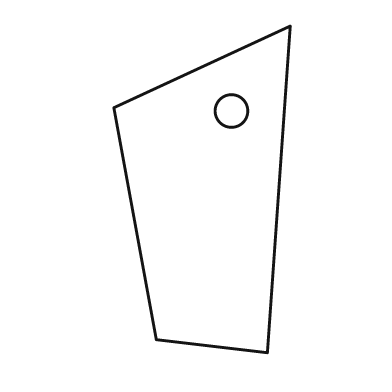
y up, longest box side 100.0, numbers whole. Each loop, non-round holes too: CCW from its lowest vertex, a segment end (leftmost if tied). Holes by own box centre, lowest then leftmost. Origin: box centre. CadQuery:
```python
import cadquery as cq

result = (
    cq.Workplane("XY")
    .moveTo(20.0, -50.0)
    .lineTo(27.0, 50.0)
    .lineTo(-27.0, 25.0)
    .lineTo(-14.0, -46.0)
    .close()
    .moveTo(9.0, 24.0)
    .circle(5.0)
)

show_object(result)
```